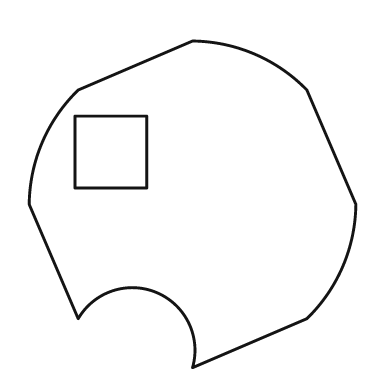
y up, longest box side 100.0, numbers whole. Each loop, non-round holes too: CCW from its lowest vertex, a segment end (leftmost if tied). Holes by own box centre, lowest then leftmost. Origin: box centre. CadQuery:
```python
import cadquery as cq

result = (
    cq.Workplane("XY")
    .moveTo(0.0, -50.0)
    .lineTo(35.0, -35.0)
    .threePointArc((46.0, -19.0), (50.0, 0.0))
    .lineTo(35.0, 35.0)
    .threePointArc((19.0, 46.0), (0.0, 50.0))
    .lineTo(-35.0, 35.0)
    .threePointArc((-46.0, 19.0), (-50.0, 0.0))
    .lineTo(-35.0, -35.0)
    .threePointArc((-11.0, -27.0), (0.0, -50.0))
    .close()
    .moveTo(-36.0, 5.0)
    .lineTo(-14.0, 5.0)
    .lineTo(-14.0, 27.0)
    .lineTo(-36.0, 27.0)
    .close()
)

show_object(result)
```